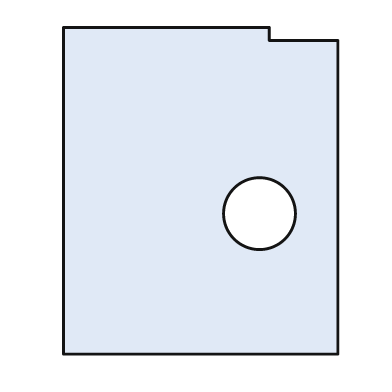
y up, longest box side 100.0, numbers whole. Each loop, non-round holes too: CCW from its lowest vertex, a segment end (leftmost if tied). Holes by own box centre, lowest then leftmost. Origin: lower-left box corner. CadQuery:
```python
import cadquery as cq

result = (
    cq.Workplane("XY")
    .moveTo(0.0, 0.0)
    .lineTo(84.0, 0.0)
    .lineTo(84.0, 96.0)
    .lineTo(63.0, 96.0)
    .lineTo(63.0, 100.0)
    .lineTo(0.0, 100.0)
    .close()
    .moveTo(60.0, 43.0)
    .circle(11.0)
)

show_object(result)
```